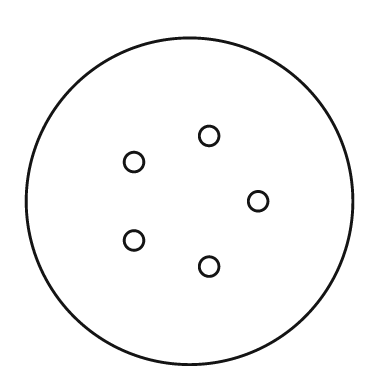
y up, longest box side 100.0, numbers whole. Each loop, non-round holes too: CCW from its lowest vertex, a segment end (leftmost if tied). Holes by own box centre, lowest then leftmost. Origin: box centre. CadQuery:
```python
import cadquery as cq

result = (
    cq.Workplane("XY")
    .moveTo(0.0, 0.0)
    .circle(50.0)
    .moveTo(6.0, -20.0)
    .circle(3.0)
    .moveTo(-17.0, -12.0)
    .circle(3.0)
    .moveTo(21.0, 0.0)
    .circle(3.0)
    .moveTo(-17.0, 12.0)
    .circle(3.0)
    .moveTo(6.0, 20.0)
    .circle(3.0)
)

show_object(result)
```